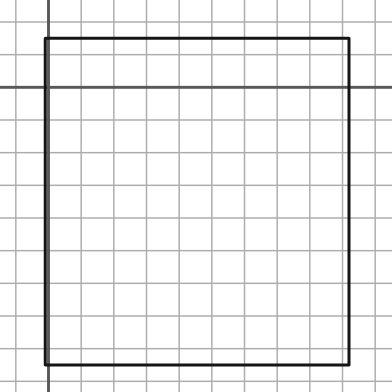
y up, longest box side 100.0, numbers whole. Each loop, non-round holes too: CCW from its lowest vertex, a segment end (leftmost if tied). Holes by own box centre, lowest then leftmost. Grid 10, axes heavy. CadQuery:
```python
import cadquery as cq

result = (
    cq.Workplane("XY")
    .moveTo(-1.0, -85.0)
    .lineTo(92.0, -85.0)
    .lineTo(92.0, 15.0)
    .lineTo(-1.0, 15.0)
    .close()
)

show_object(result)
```